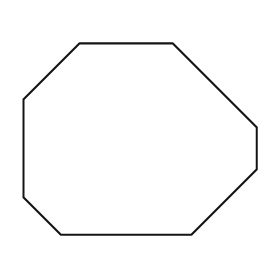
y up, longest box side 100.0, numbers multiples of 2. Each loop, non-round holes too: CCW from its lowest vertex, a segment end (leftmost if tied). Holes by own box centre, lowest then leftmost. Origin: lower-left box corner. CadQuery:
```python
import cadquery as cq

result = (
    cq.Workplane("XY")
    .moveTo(16.0, 0.0)
    .lineTo(72.0, 0.0)
    .lineTo(100.0, 28.0)
    .lineTo(100.0, 46.0)
    .lineTo(64.0, 82.0)
    .lineTo(24.0, 82.0)
    .lineTo(0.0, 58.0)
    .lineTo(0.0, 16.0)
    .close()
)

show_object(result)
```